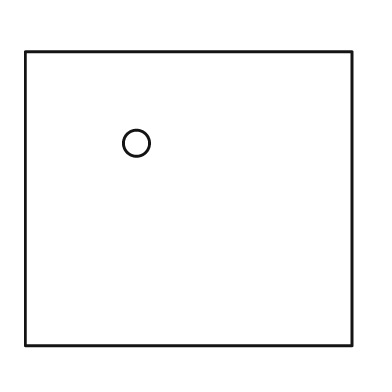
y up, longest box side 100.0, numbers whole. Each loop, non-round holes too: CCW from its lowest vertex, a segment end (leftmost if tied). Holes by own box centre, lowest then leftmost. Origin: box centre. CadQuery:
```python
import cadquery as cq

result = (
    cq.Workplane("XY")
    .moveTo(-50.0, -45.0)
    .lineTo(50.0, -45.0)
    .lineTo(50.0, 45.0)
    .lineTo(-50.0, 45.0)
    .close()
    .moveTo(-16.0, 17.0)
    .circle(4.0)
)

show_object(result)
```